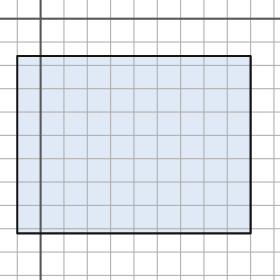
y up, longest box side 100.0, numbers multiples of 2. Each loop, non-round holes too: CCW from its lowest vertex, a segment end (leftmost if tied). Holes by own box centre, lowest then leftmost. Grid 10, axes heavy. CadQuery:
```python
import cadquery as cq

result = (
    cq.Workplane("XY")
    .moveTo(-10.0, -92.0)
    .lineTo(90.0, -92.0)
    .lineTo(90.0, -16.0)
    .lineTo(-10.0, -16.0)
    .close()
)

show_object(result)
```